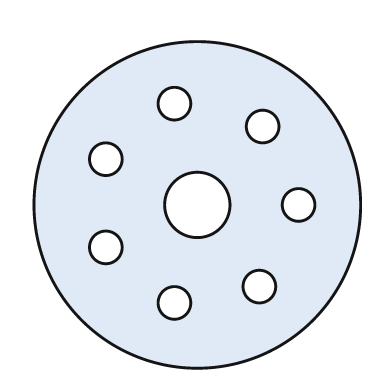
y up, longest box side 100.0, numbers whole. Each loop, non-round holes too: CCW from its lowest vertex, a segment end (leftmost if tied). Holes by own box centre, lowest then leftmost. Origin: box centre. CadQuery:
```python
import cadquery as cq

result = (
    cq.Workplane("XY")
    .moveTo(0.0, 0.0)
    .circle(50.0)
    .moveTo(-7.0, -30.0)
    .circle(5.0)
    .moveTo(19.0, -25.0)
    .circle(5.0)
    .moveTo(-28.0, -13.0)
    .circle(5.0)
    .moveTo(0.0, 0.0)
    .circle(10.0)
    .moveTo(31.0, 0.0)
    .circle(5.0)
    .moveTo(-28.0, 14.0)
    .circle(5.0)
    .moveTo(20.0, 24.0)
    .circle(5.0)
    .moveTo(-7.0, 31.0)
    .circle(5.0)
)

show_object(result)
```